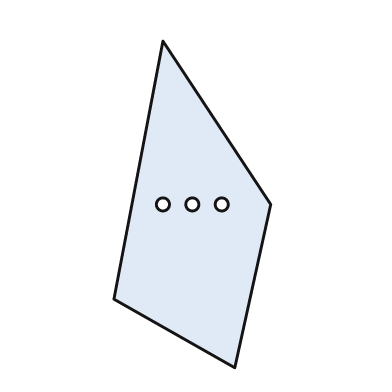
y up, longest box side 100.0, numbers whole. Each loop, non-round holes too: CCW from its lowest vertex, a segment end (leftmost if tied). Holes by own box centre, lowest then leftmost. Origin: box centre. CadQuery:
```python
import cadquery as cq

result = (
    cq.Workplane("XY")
    .moveTo(13.0, -50.0)
    .lineTo(24.0, 0.0)
    .lineTo(-9.0, 50.0)
    .lineTo(-24.0, -29.0)
    .close()
    .moveTo(-9.0, 0.0)
    .circle(2.0)
    .moveTo(0.0, 0.0)
    .circle(2.0)
    .moveTo(9.0, 0.0)
    .circle(2.0)
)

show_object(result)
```